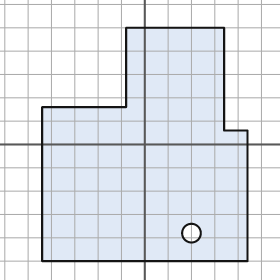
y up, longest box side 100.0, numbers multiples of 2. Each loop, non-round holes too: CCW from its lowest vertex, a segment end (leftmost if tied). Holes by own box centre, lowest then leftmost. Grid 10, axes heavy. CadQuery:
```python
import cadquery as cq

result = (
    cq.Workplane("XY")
    .moveTo(-44.0, -50.0)
    .lineTo(44.0, -50.0)
    .lineTo(44.0, 6.0)
    .lineTo(34.0, 6.0)
    .lineTo(34.0, 50.0)
    .lineTo(-8.0, 50.0)
    .lineTo(-8.0, 16.0)
    .lineTo(-44.0, 16.0)
    .close()
    .moveTo(20.0, -38.0)
    .circle(4.0)
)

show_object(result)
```